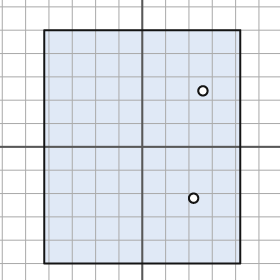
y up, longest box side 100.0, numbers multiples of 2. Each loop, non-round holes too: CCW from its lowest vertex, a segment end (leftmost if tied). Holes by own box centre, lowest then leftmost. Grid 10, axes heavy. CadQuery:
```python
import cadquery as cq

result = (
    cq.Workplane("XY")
    .moveTo(-42.0, -50.0)
    .lineTo(42.0, -50.0)
    .lineTo(42.0, 50.0)
    .lineTo(-42.0, 50.0)
    .close()
    .moveTo(22.0, -22.0)
    .circle(2.0)
    .moveTo(26.0, 24.0)
    .circle(2.0)
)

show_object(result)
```